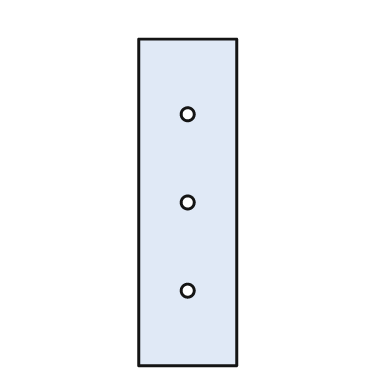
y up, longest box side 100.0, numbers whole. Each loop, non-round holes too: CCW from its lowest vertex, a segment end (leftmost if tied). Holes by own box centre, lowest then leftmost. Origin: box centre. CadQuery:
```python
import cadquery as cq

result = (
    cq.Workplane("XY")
    .moveTo(-15.0, -50.0)
    .lineTo(15.0, -50.0)
    .lineTo(15.0, 50.0)
    .lineTo(-15.0, 50.0)
    .close()
    .moveTo(0.0, -27.0)
    .circle(2.0)
    .moveTo(0.0, 0.0)
    .circle(2.0)
    .moveTo(0.0, 27.0)
    .circle(2.0)
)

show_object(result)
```